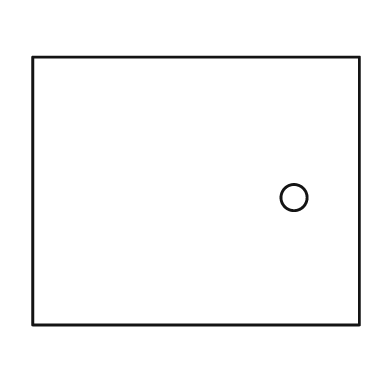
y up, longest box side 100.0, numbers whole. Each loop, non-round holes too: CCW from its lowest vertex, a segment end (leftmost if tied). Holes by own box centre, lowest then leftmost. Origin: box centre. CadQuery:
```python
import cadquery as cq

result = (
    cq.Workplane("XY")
    .moveTo(-50.0, -41.0)
    .lineTo(50.0, -41.0)
    .lineTo(50.0, 41.0)
    .lineTo(-50.0, 41.0)
    .close()
    .moveTo(30.0, -2.0)
    .circle(4.0)
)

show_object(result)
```